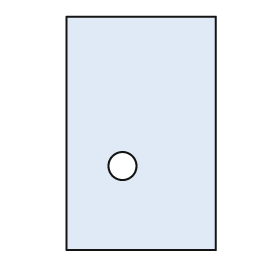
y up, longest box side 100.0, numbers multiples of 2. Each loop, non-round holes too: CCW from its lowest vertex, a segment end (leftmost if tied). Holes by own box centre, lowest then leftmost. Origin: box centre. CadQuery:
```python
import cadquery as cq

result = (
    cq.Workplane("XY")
    .moveTo(-32.0, -50.0)
    .lineTo(32.0, -50.0)
    .lineTo(32.0, 50.0)
    .lineTo(-32.0, 50.0)
    .close()
    .moveTo(-8.0, -14.0)
    .circle(6.0)
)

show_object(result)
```